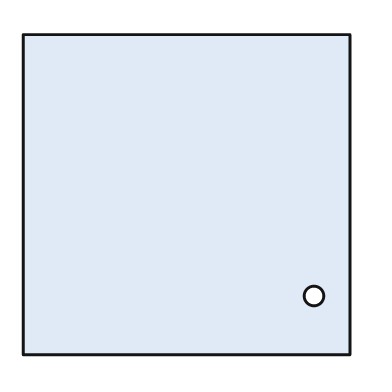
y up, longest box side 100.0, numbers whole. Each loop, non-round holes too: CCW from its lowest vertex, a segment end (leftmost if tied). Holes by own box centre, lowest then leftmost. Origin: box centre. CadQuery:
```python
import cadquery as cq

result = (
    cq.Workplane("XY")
    .moveTo(-50.0, -49.0)
    .lineTo(50.0, -49.0)
    .lineTo(50.0, 49.0)
    .lineTo(-50.0, 49.0)
    .close()
    .moveTo(39.0, -31.0)
    .circle(3.0)
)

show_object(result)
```